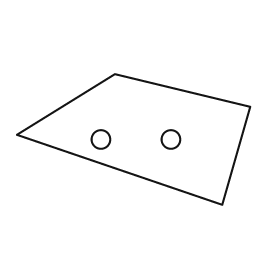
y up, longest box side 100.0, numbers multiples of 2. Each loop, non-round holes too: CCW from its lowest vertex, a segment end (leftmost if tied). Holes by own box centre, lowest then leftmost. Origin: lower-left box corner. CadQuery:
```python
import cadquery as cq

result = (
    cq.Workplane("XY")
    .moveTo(88.0, 0.0)
    .lineTo(100.0, 42.0)
    .lineTo(42.0, 56.0)
    .lineTo(0.0, 30.0)
    .close()
    .moveTo(36.0, 28.0)
    .circle(4.0)
    .moveTo(66.0, 28.0)
    .circle(4.0)
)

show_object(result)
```